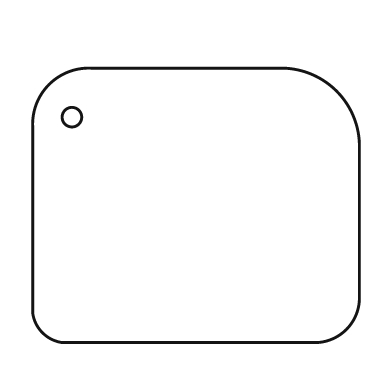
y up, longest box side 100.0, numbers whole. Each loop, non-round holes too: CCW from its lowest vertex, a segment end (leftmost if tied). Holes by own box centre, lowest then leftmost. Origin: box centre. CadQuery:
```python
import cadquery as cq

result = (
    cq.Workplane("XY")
    .moveTo(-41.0, -42.0)
    .lineTo(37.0, -42.0)
    .threePointArc((46.0, -38.0), (50.0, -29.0))
    .lineTo(50.0, 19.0)
    .threePointArc((43.0, 35.0), (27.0, 42.0))
    .lineTo(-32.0, 42.0)
    .threePointArc((-45.0, 37.0), (-50.0, 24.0))
    .lineTo(-50.0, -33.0)
    .threePointArc((-47.0, -39.0), (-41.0, -42.0))
    .close()
    .moveTo(-38.0, 27.0)
    .circle(3.0)
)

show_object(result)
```